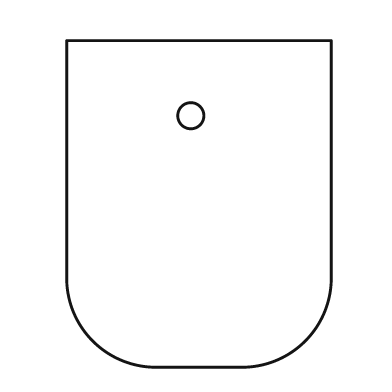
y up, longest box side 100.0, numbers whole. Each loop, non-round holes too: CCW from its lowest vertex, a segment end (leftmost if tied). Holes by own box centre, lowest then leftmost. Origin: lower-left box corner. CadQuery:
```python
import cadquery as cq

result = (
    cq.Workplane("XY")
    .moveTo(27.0, 0.0)
    .lineTo(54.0, 0.0)
    .threePointArc((73.0, 8.0), (81.0, 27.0))
    .lineTo(81.0, 100.0)
    .lineTo(0.0, 100.0)
    .lineTo(0.0, 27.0)
    .threePointArc((8.0, 8.0), (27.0, 0.0))
    .close()
    .moveTo(38.0, 77.0)
    .circle(4.0)
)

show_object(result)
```